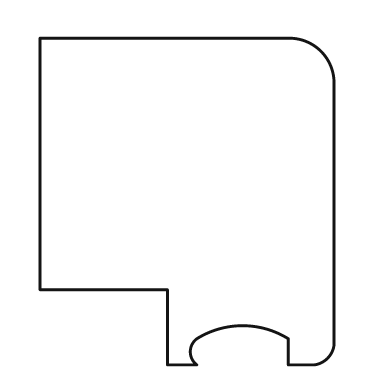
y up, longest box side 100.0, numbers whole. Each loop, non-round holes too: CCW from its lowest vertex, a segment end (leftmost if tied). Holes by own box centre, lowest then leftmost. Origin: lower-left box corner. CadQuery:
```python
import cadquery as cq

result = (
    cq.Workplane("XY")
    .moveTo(39.0, 0.0)
    .lineTo(48.0, 0.0)
    .threePointArc((46.0, 4.0), (48.0, 8.0))
    .threePointArc((62.0, 12.0), (76.0, 8.0))
    .lineTo(76.0, 0.0)
    .lineTo(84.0, 0.0)
    .threePointArc((88.0, 2.0), (90.0, 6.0))
    .lineTo(90.0, 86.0)
    .threePointArc((86.0, 96.0), (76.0, 100.0))
    .lineTo(0.0, 100.0)
    .lineTo(0.0, 23.0)
    .lineTo(39.0, 23.0)
    .close()
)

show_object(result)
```